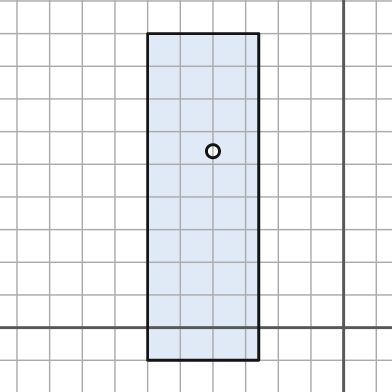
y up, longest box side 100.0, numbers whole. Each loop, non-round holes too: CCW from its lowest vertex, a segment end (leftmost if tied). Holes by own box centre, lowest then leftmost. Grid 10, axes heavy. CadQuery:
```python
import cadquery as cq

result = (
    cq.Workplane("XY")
    .moveTo(-60.0, -10.0)
    .lineTo(-26.0, -10.0)
    .lineTo(-26.0, 90.0)
    .lineTo(-60.0, 90.0)
    .close()
    .moveTo(-40.0, 54.0)
    .circle(2.0)
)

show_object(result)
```